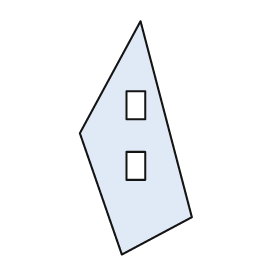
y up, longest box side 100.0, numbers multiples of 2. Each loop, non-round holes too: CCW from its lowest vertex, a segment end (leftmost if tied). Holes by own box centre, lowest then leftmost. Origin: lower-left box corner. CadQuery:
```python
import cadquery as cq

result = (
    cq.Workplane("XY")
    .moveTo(18.0, 0.0)
    .lineTo(48.0, 16.0)
    .lineTo(26.0, 100.0)
    .lineTo(0.0, 52.0)
    .close()
    .moveTo(20.0, 32.0)
    .lineTo(28.0, 32.0)
    .lineTo(28.0, 44.0)
    .lineTo(20.0, 44.0)
    .close()
    .moveTo(20.0, 58.0)
    .lineTo(28.0, 58.0)
    .lineTo(28.0, 70.0)
    .lineTo(20.0, 70.0)
    .close()
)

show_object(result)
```